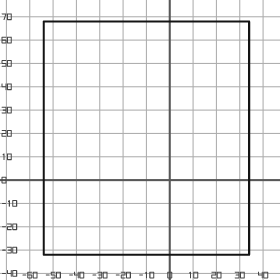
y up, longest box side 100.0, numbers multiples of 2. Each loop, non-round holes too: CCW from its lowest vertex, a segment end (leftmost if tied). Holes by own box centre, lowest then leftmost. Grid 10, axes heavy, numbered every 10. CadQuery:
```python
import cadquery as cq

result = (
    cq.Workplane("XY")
    .moveTo(-54.0, -32.0)
    .lineTo(34.0, -32.0)
    .lineTo(34.0, 68.0)
    .lineTo(-54.0, 68.0)
    .close()
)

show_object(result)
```